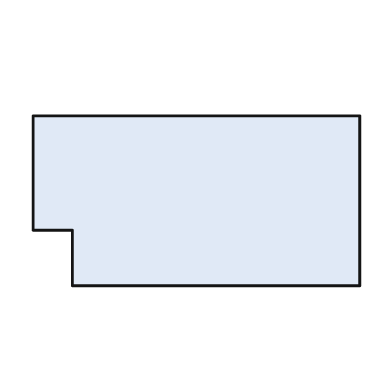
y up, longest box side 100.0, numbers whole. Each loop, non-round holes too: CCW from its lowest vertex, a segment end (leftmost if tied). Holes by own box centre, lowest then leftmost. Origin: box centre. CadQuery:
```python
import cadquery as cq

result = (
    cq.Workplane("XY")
    .moveTo(-38.0, -26.0)
    .lineTo(50.0, -26.0)
    .lineTo(50.0, 26.0)
    .lineTo(-50.0, 26.0)
    .lineTo(-50.0, -9.0)
    .lineTo(-38.0, -9.0)
    .close()
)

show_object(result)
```